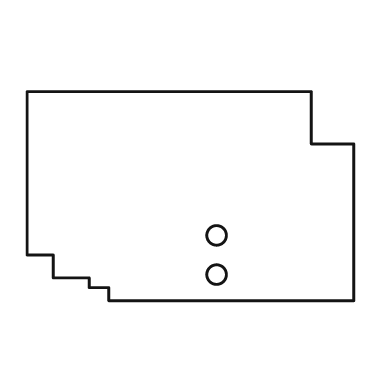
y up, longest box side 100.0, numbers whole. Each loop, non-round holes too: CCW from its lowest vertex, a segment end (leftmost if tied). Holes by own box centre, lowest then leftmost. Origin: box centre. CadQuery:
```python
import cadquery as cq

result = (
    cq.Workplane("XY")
    .moveTo(-25.0, -32.0)
    .lineTo(50.0, -32.0)
    .lineTo(50.0, 16.0)
    .lineTo(37.0, 16.0)
    .lineTo(37.0, 32.0)
    .lineTo(-50.0, 32.0)
    .lineTo(-50.0, -18.0)
    .lineTo(-42.0, -18.0)
    .lineTo(-42.0, -25.0)
    .lineTo(-31.0, -25.0)
    .lineTo(-31.0, -28.0)
    .lineTo(-25.0, -28.0)
    .close()
    .moveTo(8.0, -24.0)
    .circle(3.0)
    .moveTo(8.0, -12.0)
    .circle(3.0)
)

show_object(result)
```